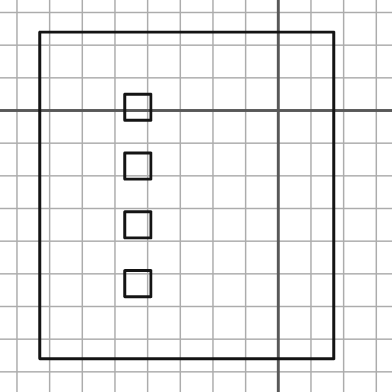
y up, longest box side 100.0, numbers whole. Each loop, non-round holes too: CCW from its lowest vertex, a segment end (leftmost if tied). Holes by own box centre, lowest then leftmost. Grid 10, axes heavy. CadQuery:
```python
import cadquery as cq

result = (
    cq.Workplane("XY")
    .moveTo(-73.0, -76.0)
    .lineTo(17.0, -76.0)
    .lineTo(17.0, 24.0)
    .lineTo(-73.0, 24.0)
    .close()
    .moveTo(-47.0, -57.0)
    .lineTo(-39.0, -57.0)
    .lineTo(-39.0, -49.0)
    .lineTo(-47.0, -49.0)
    .close()
    .moveTo(-47.0, -39.0)
    .lineTo(-39.0, -39.0)
    .lineTo(-39.0, -31.0)
    .lineTo(-47.0, -31.0)
    .close()
    .moveTo(-47.0, -21.0)
    .lineTo(-39.0, -21.0)
    .lineTo(-39.0, -13.0)
    .lineTo(-47.0, -13.0)
    .close()
    .moveTo(-47.0, -3.0)
    .lineTo(-39.0, -3.0)
    .lineTo(-39.0, 5.0)
    .lineTo(-47.0, 5.0)
    .close()
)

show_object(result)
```